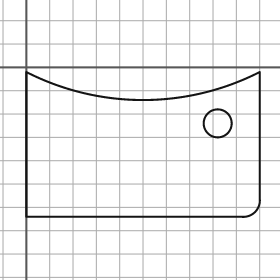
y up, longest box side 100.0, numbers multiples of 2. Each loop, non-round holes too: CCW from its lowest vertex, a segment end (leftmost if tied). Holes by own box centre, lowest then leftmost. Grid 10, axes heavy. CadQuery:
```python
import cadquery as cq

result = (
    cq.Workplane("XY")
    .moveTo(0.0, -64.0)
    .lineTo(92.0, -64.0)
    .threePointArc((98.0, -62.0), (100.0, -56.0))
    .lineTo(100.0, -2.0)
    .threePointArc((50.0, -14.0), (0.0, -2.0))
    .close()
    .moveTo(82.0, -24.0)
    .circle(6.0)
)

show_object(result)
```